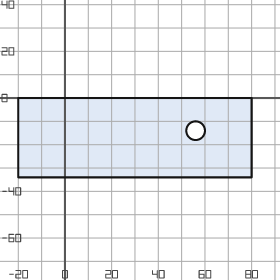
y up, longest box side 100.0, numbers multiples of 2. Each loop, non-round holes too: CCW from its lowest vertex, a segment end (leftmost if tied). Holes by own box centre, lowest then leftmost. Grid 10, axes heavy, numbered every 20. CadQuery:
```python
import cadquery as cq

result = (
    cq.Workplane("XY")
    .moveTo(-20.0, -34.0)
    .lineTo(80.0, -34.0)
    .lineTo(80.0, 0.0)
    .lineTo(-20.0, 0.0)
    .close()
    .moveTo(56.0, -14.0)
    .circle(4.0)
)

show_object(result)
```